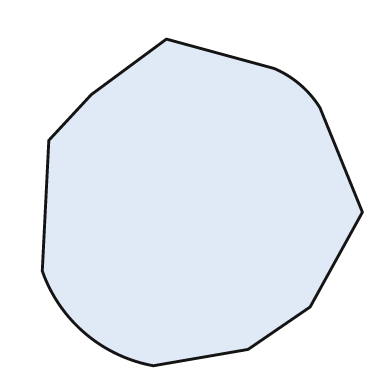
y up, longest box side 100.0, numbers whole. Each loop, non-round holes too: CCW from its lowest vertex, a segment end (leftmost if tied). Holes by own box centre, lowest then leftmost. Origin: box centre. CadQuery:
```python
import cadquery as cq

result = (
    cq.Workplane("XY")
    .moveTo(-15.0, -50.0)
    .lineTo(14.0, -45.0)
    .lineTo(33.0, -32.0)
    .lineTo(49.0, -3.0)
    .lineTo(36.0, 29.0)
    .threePointArc((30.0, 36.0), (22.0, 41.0))
    .lineTo(-11.0, 50.0)
    .lineTo(-34.0, 33.0)
    .lineTo(-47.0, 19.0)
    .lineTo(-49.0, -21.0)
    .threePointArc((-36.0, -40.0), (-15.0, -50.0))
    .close()
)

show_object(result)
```